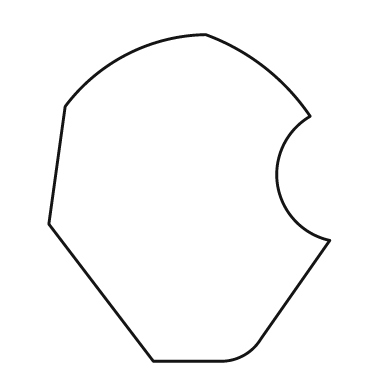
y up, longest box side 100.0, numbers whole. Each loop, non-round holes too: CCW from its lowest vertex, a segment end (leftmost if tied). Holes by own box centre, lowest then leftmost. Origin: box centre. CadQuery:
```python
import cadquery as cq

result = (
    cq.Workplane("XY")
    .moveTo(-11.0, -50.0)
    .lineTo(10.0, -50.0)
    .threePointArc((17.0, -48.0), (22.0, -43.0))
    .lineTo(43.0, -13.0)
    .threePointArc((27.0, 4.0), (37.0, 25.0))
    .threePointArc((23.0, 40.0), (5.0, 50.0))
    .threePointArc((-19.0, 44.0), (-38.0, 28.0))
    .lineTo(-43.0, -8.0)
    .close()
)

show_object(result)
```